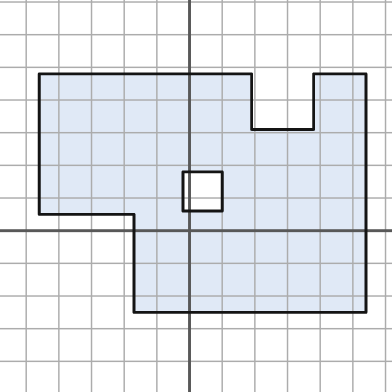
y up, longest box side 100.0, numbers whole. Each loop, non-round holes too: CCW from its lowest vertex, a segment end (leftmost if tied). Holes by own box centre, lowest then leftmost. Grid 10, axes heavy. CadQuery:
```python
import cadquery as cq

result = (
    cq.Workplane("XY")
    .moveTo(-17.0, -25.0)
    .lineTo(54.0, -25.0)
    .lineTo(54.0, 48.0)
    .lineTo(38.0, 48.0)
    .lineTo(38.0, 31.0)
    .lineTo(19.0, 31.0)
    .lineTo(19.0, 48.0)
    .lineTo(-46.0, 48.0)
    .lineTo(-46.0, 5.0)
    .lineTo(-17.0, 5.0)
    .close()
    .moveTo(-2.0, 6.0)
    .lineTo(10.0, 6.0)
    .lineTo(10.0, 18.0)
    .lineTo(-2.0, 18.0)
    .close()
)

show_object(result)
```